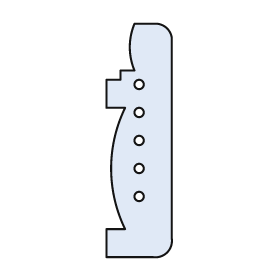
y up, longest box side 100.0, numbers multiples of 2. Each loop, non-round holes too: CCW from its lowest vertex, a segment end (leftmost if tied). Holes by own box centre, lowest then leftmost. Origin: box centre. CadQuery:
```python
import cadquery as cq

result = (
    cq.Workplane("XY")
    .moveTo(-14.0, -50.0)
    .lineTo(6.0, -50.0)
    .threePointArc((12.0, -48.0), (14.0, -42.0))
    .lineTo(14.0, 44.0)
    .threePointArc((12.0, 48.0), (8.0, 50.0))
    .lineTo(-2.0, 50.0)
    .threePointArc((-4.0, 40.0), (-2.0, 30.0))
    .lineTo(-8.0, 30.0)
    .lineTo(-8.0, 26.0)
    .lineTo(-14.0, 26.0)
    .lineTo(-14.0, 14.0)
    .lineTo(-6.0, 14.0)
    .threePointArc((-12.0, -12.0), (-6.0, -38.0))
    .lineTo(-14.0, -38.0)
    .close()
    .moveTo(0.0, -24.0)
    .circle(2.0)
    .moveTo(0.0, -12.0)
    .circle(2.0)
    .moveTo(0.0, 0.0)
    .circle(2.0)
    .moveTo(0.0, 12.0)
    .circle(2.0)
    .moveTo(0.0, 24.0)
    .circle(2.0)
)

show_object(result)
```